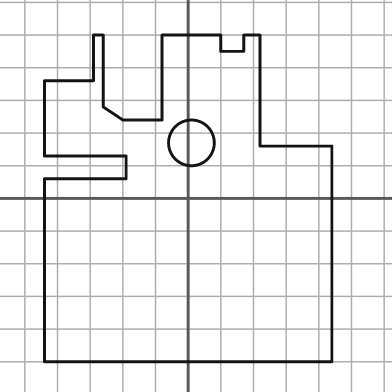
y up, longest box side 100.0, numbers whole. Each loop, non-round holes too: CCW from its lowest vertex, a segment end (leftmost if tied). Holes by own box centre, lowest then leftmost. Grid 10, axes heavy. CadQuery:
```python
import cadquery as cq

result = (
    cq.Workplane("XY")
    .moveTo(-44.0, -50.0)
    .lineTo(44.0, -50.0)
    .lineTo(44.0, 16.0)
    .lineTo(22.0, 16.0)
    .lineTo(22.0, 50.0)
    .lineTo(17.0, 50.0)
    .lineTo(17.0, 45.0)
    .lineTo(10.0, 45.0)
    .lineTo(10.0, 50.0)
    .lineTo(-8.0, 50.0)
    .lineTo(-8.0, 24.0)
    .lineTo(-20.0, 24.0)
    .lineTo(-26.0, 28.0)
    .lineTo(-26.0, 50.0)
    .lineTo(-29.0, 50.0)
    .lineTo(-29.0, 36.0)
    .lineTo(-44.0, 36.0)
    .lineTo(-44.0, 13.0)
    .lineTo(-19.0, 13.0)
    .lineTo(-19.0, 6.0)
    .lineTo(-44.0, 6.0)
    .close()
    .moveTo(1.0, 17.0)
    .circle(7.0)
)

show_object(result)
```